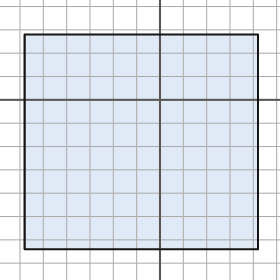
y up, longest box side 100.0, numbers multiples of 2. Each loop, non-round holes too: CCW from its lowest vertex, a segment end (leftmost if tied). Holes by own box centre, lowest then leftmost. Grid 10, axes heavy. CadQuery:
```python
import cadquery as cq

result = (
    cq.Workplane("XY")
    .moveTo(-58.0, -64.0)
    .lineTo(42.0, -64.0)
    .lineTo(42.0, 28.0)
    .lineTo(-58.0, 28.0)
    .close()
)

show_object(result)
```